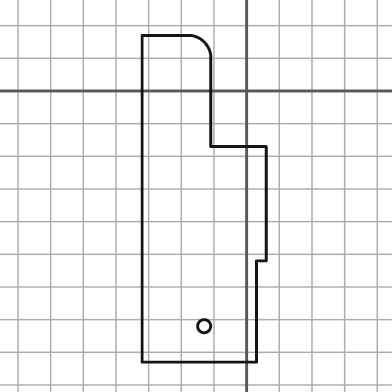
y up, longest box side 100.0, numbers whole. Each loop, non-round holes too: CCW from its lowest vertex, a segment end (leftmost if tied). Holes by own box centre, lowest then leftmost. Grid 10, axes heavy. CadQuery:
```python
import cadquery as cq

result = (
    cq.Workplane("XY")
    .moveTo(-32.0, -83.0)
    .lineTo(3.0, -83.0)
    .lineTo(3.0, -52.0)
    .lineTo(6.0, -52.0)
    .lineTo(6.0, -17.0)
    .lineTo(-11.0, -17.0)
    .lineTo(-11.0, 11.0)
    .threePointArc((-13.0, 15.0), (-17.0, 17.0))
    .lineTo(-32.0, 17.0)
    .close()
    .moveTo(-13.0, -72.0)
    .circle(2.0)
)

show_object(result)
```